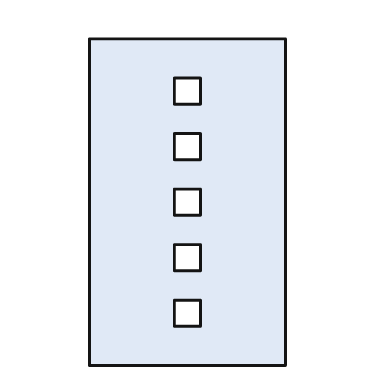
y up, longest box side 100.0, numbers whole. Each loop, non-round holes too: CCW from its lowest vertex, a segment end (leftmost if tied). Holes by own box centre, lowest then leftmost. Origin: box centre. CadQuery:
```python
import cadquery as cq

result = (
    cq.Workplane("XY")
    .moveTo(-30.0, -50.0)
    .lineTo(30.0, -50.0)
    .lineTo(30.0, 50.0)
    .lineTo(-30.0, 50.0)
    .close()
    .moveTo(-4.0, -38.0)
    .lineTo(4.0, -38.0)
    .lineTo(4.0, -30.0)
    .lineTo(-4.0, -30.0)
    .close()
    .moveTo(-4.0, -21.0)
    .lineTo(4.0, -21.0)
    .lineTo(4.0, -13.0)
    .lineTo(-4.0, -13.0)
    .close()
    .moveTo(-4.0, -4.0)
    .lineTo(4.0, -4.0)
    .lineTo(4.0, 4.0)
    .lineTo(-4.0, 4.0)
    .close()
    .moveTo(-4.0, 13.0)
    .lineTo(4.0, 13.0)
    .lineTo(4.0, 21.0)
    .lineTo(-4.0, 21.0)
    .close()
    .moveTo(-4.0, 30.0)
    .lineTo(4.0, 30.0)
    .lineTo(4.0, 38.0)
    .lineTo(-4.0, 38.0)
    .close()
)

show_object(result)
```